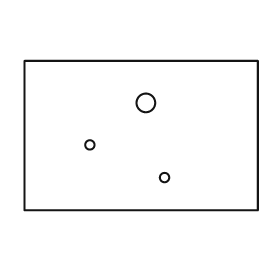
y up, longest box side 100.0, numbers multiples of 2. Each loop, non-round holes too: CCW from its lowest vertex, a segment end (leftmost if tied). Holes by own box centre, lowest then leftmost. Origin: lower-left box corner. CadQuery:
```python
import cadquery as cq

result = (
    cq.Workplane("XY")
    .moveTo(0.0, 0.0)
    .lineTo(100.0, 0.0)
    .lineTo(100.0, 64.0)
    .lineTo(0.0, 64.0)
    .close()
    .moveTo(60.0, 14.0)
    .circle(2.0)
    .moveTo(28.0, 28.0)
    .circle(2.0)
    .moveTo(52.0, 46.0)
    .circle(4.0)
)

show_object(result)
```